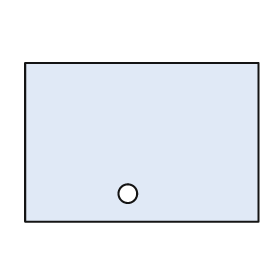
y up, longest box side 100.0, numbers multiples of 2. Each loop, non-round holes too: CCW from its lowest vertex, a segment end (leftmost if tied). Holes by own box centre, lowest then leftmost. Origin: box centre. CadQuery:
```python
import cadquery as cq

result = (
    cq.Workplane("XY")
    .moveTo(-50.0, -34.0)
    .lineTo(50.0, -34.0)
    .lineTo(50.0, 34.0)
    .lineTo(-50.0, 34.0)
    .close()
    .moveTo(-6.0, -22.0)
    .circle(4.0)
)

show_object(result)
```